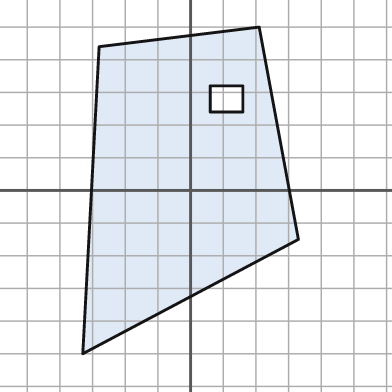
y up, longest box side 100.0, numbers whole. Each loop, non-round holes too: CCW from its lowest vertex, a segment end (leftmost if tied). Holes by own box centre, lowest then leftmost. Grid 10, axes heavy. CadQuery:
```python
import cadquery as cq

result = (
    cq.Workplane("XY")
    .moveTo(-33.0, -50.0)
    .lineTo(33.0, -15.0)
    .lineTo(21.0, 50.0)
    .lineTo(-28.0, 44.0)
    .close()
    .moveTo(6.0, 24.0)
    .lineTo(16.0, 24.0)
    .lineTo(16.0, 32.0)
    .lineTo(6.0, 32.0)
    .close()
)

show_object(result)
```